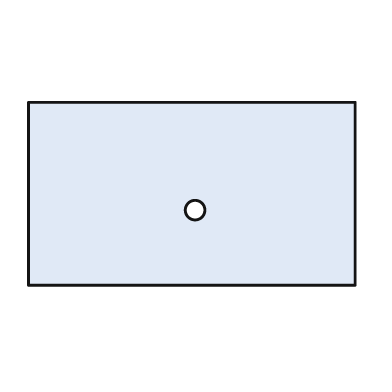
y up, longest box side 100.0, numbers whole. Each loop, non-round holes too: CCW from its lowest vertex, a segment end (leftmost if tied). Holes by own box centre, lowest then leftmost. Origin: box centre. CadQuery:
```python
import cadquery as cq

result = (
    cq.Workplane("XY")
    .moveTo(-50.0, -28.0)
    .lineTo(50.0, -28.0)
    .lineTo(50.0, 28.0)
    .lineTo(-50.0, 28.0)
    .close()
    .moveTo(1.0, -5.0)
    .circle(3.0)
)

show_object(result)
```